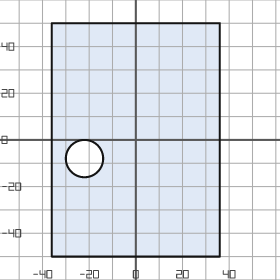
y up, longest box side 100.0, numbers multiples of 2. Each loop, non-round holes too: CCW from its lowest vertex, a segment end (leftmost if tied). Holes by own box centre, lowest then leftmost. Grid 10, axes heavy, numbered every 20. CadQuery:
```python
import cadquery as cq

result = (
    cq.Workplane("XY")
    .moveTo(-36.0, -50.0)
    .lineTo(36.0, -50.0)
    .lineTo(36.0, 50.0)
    .lineTo(-36.0, 50.0)
    .close()
    .moveTo(-22.0, -8.0)
    .circle(8.0)
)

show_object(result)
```